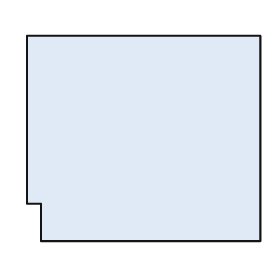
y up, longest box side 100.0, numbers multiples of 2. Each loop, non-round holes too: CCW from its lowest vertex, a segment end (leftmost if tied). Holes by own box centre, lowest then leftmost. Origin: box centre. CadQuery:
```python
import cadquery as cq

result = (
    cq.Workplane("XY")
    .moveTo(-44.0, -44.0)
    .lineTo(50.0, -44.0)
    .lineTo(50.0, 44.0)
    .lineTo(-50.0, 44.0)
    .lineTo(-50.0, -28.0)
    .lineTo(-44.0, -28.0)
    .close()
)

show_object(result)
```